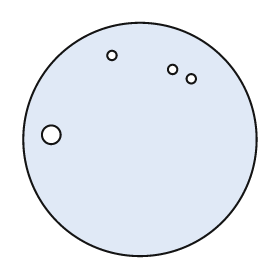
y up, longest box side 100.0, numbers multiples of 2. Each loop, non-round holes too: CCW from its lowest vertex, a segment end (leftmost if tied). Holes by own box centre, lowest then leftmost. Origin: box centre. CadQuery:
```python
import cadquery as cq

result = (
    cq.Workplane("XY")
    .moveTo(0.0, 0.0)
    .circle(50.0)
    .moveTo(-38.0, 2.0)
    .circle(4.0)
    .moveTo(22.0, 26.0)
    .circle(2.0)
    .moveTo(14.0, 30.0)
    .circle(2.0)
    .moveTo(-12.0, 36.0)
    .circle(2.0)
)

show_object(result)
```